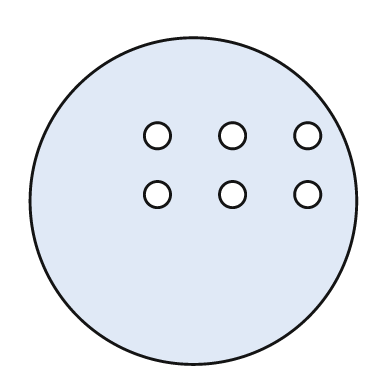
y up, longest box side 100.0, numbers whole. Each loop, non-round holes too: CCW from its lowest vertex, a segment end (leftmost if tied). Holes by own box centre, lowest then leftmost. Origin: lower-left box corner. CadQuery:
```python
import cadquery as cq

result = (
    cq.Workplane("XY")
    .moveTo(50.0, 50.0)
    .circle(50.0)
    .moveTo(39.0, 52.0)
    .circle(4.0)
    .moveTo(62.0, 52.0)
    .circle(4.0)
    .moveTo(85.0, 52.0)
    .circle(4.0)
    .moveTo(39.0, 70.0)
    .circle(4.0)
    .moveTo(62.0, 70.0)
    .circle(4.0)
    .moveTo(85.0, 70.0)
    .circle(4.0)
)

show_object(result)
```